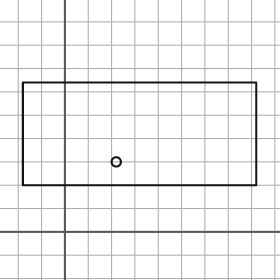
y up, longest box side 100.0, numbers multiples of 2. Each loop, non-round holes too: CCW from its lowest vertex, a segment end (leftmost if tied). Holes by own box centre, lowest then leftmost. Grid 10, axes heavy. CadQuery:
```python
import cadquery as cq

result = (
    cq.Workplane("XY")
    .moveTo(-18.0, 20.0)
    .lineTo(82.0, 20.0)
    .lineTo(82.0, 64.0)
    .lineTo(-18.0, 64.0)
    .close()
    .moveTo(22.0, 30.0)
    .circle(2.0)
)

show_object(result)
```